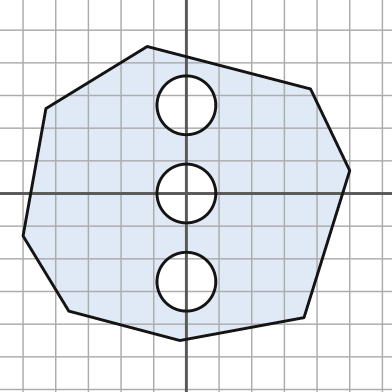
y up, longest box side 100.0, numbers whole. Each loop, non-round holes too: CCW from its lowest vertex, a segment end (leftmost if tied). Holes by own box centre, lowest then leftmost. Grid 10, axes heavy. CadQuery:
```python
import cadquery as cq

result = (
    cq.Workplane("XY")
    .moveTo(-2.0, -45.0)
    .lineTo(36.0, -38.0)
    .lineTo(50.0, 7.0)
    .lineTo(38.0, 32.0)
    .lineTo(-12.0, 45.0)
    .lineTo(-43.0, 26.0)
    .lineTo(-50.0, -13.0)
    .lineTo(-36.0, -36.0)
    .close()
    .moveTo(0.0, -27.0)
    .circle(9.0)
    .moveTo(0.0, 0.0)
    .circle(9.0)
    .moveTo(0.0, 27.0)
    .circle(9.0)
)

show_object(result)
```